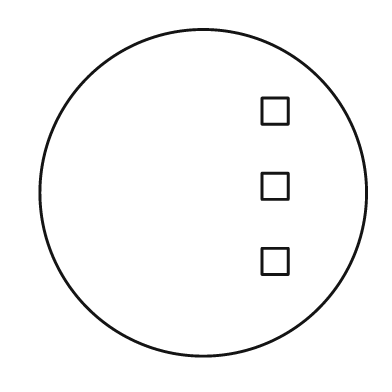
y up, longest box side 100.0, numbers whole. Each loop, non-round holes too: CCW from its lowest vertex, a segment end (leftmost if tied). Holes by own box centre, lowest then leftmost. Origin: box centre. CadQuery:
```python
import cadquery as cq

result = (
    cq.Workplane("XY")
    .moveTo(0.0, 0.0)
    .circle(50.0)
    .moveTo(18.0, -25.0)
    .lineTo(26.0, -25.0)
    .lineTo(26.0, -17.0)
    .lineTo(18.0, -17.0)
    .close()
    .moveTo(18.0, -2.0)
    .lineTo(26.0, -2.0)
    .lineTo(26.0, 6.0)
    .lineTo(18.0, 6.0)
    .close()
    .moveTo(18.0, 21.0)
    .lineTo(26.0, 21.0)
    .lineTo(26.0, 29.0)
    .lineTo(18.0, 29.0)
    .close()
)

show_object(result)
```